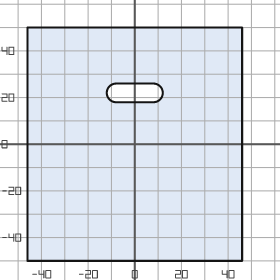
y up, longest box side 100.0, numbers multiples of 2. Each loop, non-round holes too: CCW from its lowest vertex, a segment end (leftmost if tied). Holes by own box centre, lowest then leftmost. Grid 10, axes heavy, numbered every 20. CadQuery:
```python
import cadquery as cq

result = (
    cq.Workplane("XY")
    .moveTo(-46.0, -50.0)
    .lineTo(46.0, -50.0)
    .lineTo(46.0, 50.0)
    .lineTo(-46.0, 50.0)
    .close()
    .moveTo(-8.0, 18.0)
    .lineTo(8.0, 18.0)
    .threePointArc((12.0, 22.0), (8.0, 26.0))
    .lineTo(-8.0, 26.0)
    .threePointArc((-12.0, 22.0), (-8.0, 18.0))
    .close()
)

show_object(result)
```